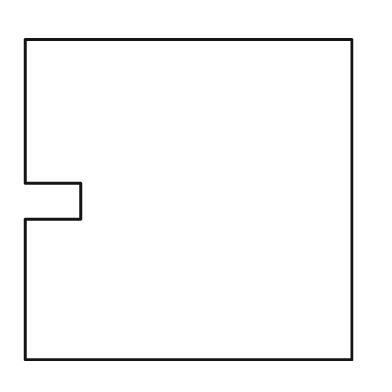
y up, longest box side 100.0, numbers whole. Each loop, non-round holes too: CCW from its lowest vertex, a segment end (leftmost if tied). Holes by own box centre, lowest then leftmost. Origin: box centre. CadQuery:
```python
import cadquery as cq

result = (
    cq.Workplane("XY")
    .moveTo(-50.0, -49.0)
    .lineTo(50.0, -49.0)
    .lineTo(50.0, 49.0)
    .lineTo(-50.0, 49.0)
    .lineTo(-50.0, 5.0)
    .lineTo(-33.0, 5.0)
    .lineTo(-33.0, -6.0)
    .lineTo(-50.0, -6.0)
    .close()
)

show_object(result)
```